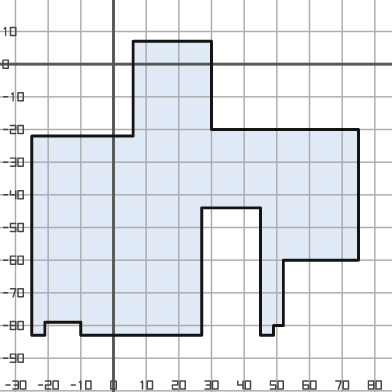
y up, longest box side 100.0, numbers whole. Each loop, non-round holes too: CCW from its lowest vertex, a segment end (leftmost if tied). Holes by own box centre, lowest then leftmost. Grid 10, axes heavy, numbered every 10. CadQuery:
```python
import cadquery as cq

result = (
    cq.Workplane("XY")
    .moveTo(-25.0, -83.0)
    .lineTo(-21.0, -83.0)
    .lineTo(-21.0, -79.0)
    .lineTo(-10.0, -79.0)
    .lineTo(-10.0, -83.0)
    .lineTo(27.0, -83.0)
    .lineTo(27.0, -44.0)
    .lineTo(45.0, -44.0)
    .lineTo(45.0, -83.0)
    .lineTo(49.0, -83.0)
    .lineTo(49.0, -80.0)
    .lineTo(52.0, -80.0)
    .lineTo(52.0, -60.0)
    .lineTo(75.0, -60.0)
    .lineTo(75.0, -20.0)
    .lineTo(30.0, -20.0)
    .lineTo(30.0, 7.0)
    .lineTo(6.0, 7.0)
    .lineTo(6.0, -22.0)
    .lineTo(-25.0, -22.0)
    .close()
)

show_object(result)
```